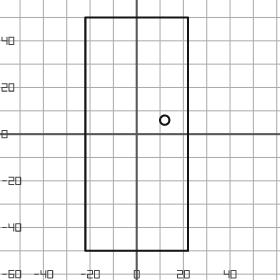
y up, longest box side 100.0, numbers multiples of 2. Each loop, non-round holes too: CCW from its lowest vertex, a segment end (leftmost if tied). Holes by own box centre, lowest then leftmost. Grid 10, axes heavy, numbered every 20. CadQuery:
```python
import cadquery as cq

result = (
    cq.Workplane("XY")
    .moveTo(-22.0, -50.0)
    .lineTo(22.0, -50.0)
    .lineTo(22.0, 50.0)
    .lineTo(-22.0, 50.0)
    .close()
    .moveTo(12.0, 6.0)
    .circle(2.0)
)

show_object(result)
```